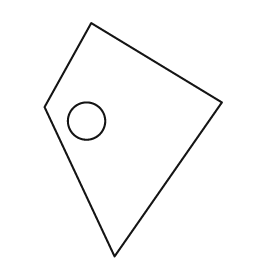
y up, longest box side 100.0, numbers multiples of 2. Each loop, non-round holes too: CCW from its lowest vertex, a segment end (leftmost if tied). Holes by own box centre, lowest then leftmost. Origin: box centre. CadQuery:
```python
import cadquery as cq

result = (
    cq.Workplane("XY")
    .moveTo(-8.0, -50.0)
    .lineTo(38.0, 16.0)
    .lineTo(-18.0, 50.0)
    .lineTo(-38.0, 14.0)
    .close()
    .moveTo(-20.0, 8.0)
    .circle(8.0)
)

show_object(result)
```